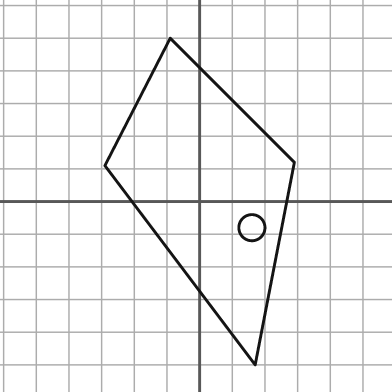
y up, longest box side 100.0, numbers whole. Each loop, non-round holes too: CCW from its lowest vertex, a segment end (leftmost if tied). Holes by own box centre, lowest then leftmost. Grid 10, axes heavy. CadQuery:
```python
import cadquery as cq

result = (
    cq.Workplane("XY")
    .moveTo(17.0, -50.0)
    .lineTo(29.0, 12.0)
    .lineTo(-9.0, 50.0)
    .lineTo(-29.0, 11.0)
    .close()
    .moveTo(16.0, -8.0)
    .circle(4.0)
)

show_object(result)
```